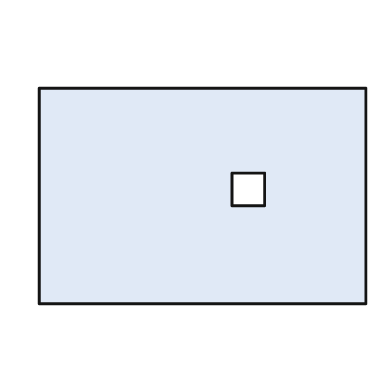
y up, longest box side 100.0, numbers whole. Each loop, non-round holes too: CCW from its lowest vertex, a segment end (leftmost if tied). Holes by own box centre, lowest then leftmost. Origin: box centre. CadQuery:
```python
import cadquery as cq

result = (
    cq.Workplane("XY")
    .moveTo(-50.0, -33.0)
    .lineTo(50.0, -33.0)
    .lineTo(50.0, 33.0)
    .lineTo(-50.0, 33.0)
    .close()
    .moveTo(9.0, -3.0)
    .lineTo(19.0, -3.0)
    .lineTo(19.0, 7.0)
    .lineTo(9.0, 7.0)
    .close()
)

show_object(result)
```